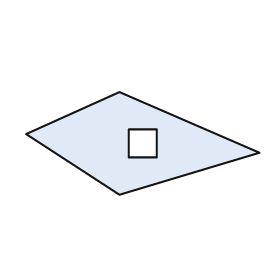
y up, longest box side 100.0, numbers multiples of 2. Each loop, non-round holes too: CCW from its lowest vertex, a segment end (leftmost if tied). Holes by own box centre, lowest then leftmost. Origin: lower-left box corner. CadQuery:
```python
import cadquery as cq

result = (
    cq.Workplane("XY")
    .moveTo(40.0, 0.0)
    .lineTo(100.0, 18.0)
    .lineTo(40.0, 44.0)
    .lineTo(0.0, 26.0)
    .close()
    .moveTo(44.0, 16.0)
    .lineTo(56.0, 16.0)
    .lineTo(56.0, 28.0)
    .lineTo(44.0, 28.0)
    .close()
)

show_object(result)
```